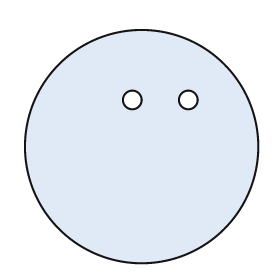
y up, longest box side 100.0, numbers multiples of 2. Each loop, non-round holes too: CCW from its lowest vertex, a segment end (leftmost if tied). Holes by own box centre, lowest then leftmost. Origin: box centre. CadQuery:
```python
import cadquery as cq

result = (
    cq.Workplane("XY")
    .moveTo(0.0, 0.0)
    .circle(50.0)
    .moveTo(-4.0, 20.0)
    .circle(4.0)
    .moveTo(20.0, 20.0)
    .circle(4.0)
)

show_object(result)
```